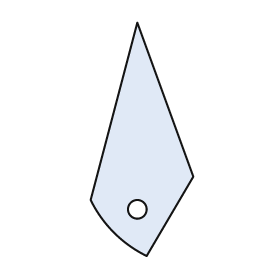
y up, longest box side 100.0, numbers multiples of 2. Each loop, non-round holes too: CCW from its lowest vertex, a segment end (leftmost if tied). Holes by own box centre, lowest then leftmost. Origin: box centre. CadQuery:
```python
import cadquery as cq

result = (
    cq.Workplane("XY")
    .moveTo(2.0, -50.0)
    .lineTo(22.0, -16.0)
    .lineTo(-2.0, 50.0)
    .lineTo(-22.0, -26.0)
    .threePointArc((-12.0, -40.0), (2.0, -50.0))
    .close()
    .moveTo(-2.0, -30.0)
    .circle(4.0)
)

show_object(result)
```